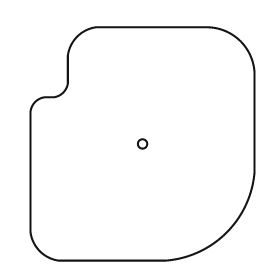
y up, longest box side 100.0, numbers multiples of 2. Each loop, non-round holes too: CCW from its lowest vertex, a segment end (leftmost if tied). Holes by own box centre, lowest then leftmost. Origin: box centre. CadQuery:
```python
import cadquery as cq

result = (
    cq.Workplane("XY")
    .moveTo(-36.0, -50.0)
    .lineTo(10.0, -50.0)
    .threePointArc((36.0, -38.0), (48.0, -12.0))
    .lineTo(48.0, 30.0)
    .threePointArc((42.0, 44.0), (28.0, 50.0))
    .lineTo(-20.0, 50.0)
    .threePointArc((-28.0, 46.0), (-32.0, 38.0))
    .lineTo(-32.0, 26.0)
    .threePointArc((-34.0, 22.0), (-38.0, 20.0))
    .lineTo(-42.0, 20.0)
    .threePointArc((-46.0, 18.0), (-48.0, 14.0))
    .lineTo(-48.0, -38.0)
    .threePointArc((-44.0, -46.0), (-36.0, -50.0))
    .close()
    .moveTo(0.0, 0.0)
    .circle(2.0)
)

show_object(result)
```